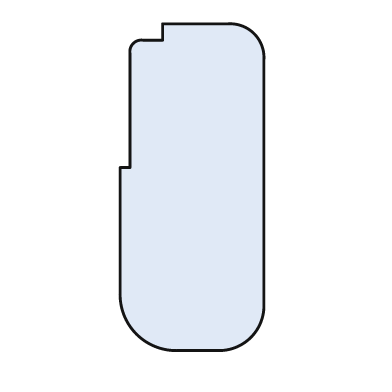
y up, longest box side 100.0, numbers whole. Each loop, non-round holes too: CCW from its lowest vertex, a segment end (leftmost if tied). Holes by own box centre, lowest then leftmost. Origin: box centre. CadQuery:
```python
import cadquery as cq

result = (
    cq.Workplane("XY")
    .moveTo(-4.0, -50.0)
    .lineTo(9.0, -50.0)
    .threePointArc((18.0, -46.0), (22.0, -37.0))
    .lineTo(22.0, 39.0)
    .threePointArc((19.0, 47.0), (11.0, 50.0))
    .lineTo(-9.0, 50.0)
    .lineTo(-9.0, 45.0)
    .lineTo(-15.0, 45.0)
    .threePointArc((-18.0, 44.0), (-19.0, 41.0))
    .lineTo(-19.0, 6.0)
    .lineTo(-22.0, 6.0)
    .lineTo(-22.0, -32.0)
    .threePointArc((-17.0, -45.0), (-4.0, -50.0))
    .close()
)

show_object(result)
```